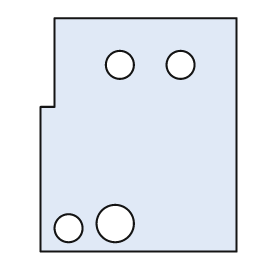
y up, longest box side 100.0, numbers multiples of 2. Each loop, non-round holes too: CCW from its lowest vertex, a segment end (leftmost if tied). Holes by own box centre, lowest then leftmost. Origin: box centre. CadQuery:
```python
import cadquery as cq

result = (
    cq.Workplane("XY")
    .moveTo(-42.0, -50.0)
    .lineTo(42.0, -50.0)
    .lineTo(42.0, 50.0)
    .lineTo(-36.0, 50.0)
    .lineTo(-36.0, 12.0)
    .lineTo(-42.0, 12.0)
    .close()
    .moveTo(-30.0, -40.0)
    .circle(6.0)
    .moveTo(-10.0, -38.0)
    .circle(8.0)
    .moveTo(-8.0, 30.0)
    .circle(6.0)
    .moveTo(18.0, 30.0)
    .circle(6.0)
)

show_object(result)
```